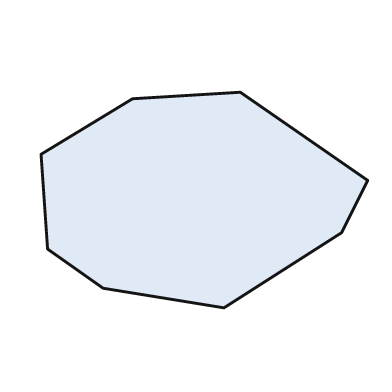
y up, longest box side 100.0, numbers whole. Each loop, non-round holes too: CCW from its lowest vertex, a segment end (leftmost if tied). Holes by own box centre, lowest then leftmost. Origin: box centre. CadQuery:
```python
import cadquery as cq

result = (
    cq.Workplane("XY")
    .moveTo(6.0, -33.0)
    .lineTo(42.0, -10.0)
    .lineTo(50.0, 6.0)
    .lineTo(11.0, 33.0)
    .lineTo(-22.0, 31.0)
    .lineTo(-50.0, 14.0)
    .lineTo(-48.0, -15.0)
    .lineTo(-31.0, -27.0)
    .close()
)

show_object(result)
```